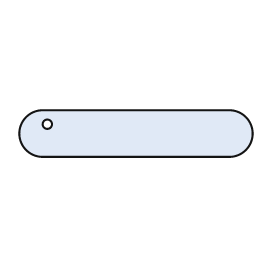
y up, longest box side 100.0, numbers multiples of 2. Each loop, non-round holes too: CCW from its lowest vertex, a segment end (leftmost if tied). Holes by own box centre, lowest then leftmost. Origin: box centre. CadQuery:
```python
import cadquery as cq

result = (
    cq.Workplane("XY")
    .moveTo(-40.0, -10.0)
    .lineTo(40.0, -10.0)
    .threePointArc((50.0, 0.0), (40.0, 10.0))
    .lineTo(-40.0, 10.0)
    .threePointArc((-50.0, 0.0), (-40.0, -10.0))
    .close()
    .moveTo(-38.0, 4.0)
    .circle(2.0)
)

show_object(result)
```